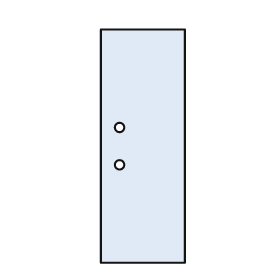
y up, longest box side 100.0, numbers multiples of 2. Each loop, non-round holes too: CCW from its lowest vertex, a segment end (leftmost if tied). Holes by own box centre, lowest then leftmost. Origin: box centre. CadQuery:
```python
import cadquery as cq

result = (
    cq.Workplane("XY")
    .moveTo(-18.0, -50.0)
    .lineTo(18.0, -50.0)
    .lineTo(18.0, 50.0)
    .lineTo(-18.0, 50.0)
    .close()
    .moveTo(-10.0, -8.0)
    .circle(2.0)
    .moveTo(-10.0, 8.0)
    .circle(2.0)
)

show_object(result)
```